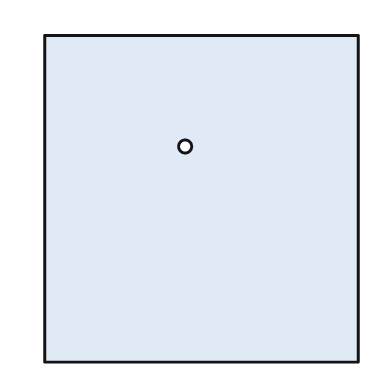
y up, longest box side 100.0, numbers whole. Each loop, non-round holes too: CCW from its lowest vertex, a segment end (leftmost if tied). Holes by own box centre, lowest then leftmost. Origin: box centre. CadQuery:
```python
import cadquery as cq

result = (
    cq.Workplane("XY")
    .moveTo(-48.0, -50.0)
    .lineTo(48.0, -50.0)
    .lineTo(48.0, 50.0)
    .lineTo(-48.0, 50.0)
    .close()
    .moveTo(-5.0, 16.0)
    .circle(2.0)
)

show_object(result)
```